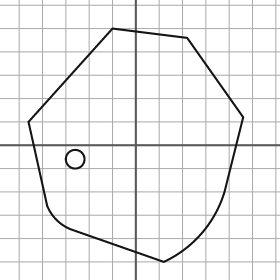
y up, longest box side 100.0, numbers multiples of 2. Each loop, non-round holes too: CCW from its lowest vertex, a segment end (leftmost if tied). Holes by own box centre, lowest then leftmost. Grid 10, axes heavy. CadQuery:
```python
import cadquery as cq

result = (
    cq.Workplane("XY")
    .moveTo(12.0, -50.0)
    .threePointArc((28.0, -38.0), (38.0, -20.0))
    .lineTo(46.0, 12.0)
    .lineTo(22.0, 46.0)
    .lineTo(-10.0, 50.0)
    .lineTo(-46.0, 10.0)
    .lineTo(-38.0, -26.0)
    .threePointArc((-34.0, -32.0), (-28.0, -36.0))
    .close()
    .moveTo(-26.0, -6.0)
    .circle(4.0)
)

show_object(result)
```